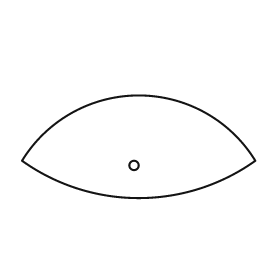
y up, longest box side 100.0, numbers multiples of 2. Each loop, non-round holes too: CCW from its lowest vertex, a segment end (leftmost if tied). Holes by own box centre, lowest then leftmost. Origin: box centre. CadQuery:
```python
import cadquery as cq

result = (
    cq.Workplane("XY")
    .moveTo(-50.0, -6.0)
    .threePointArc((0.0, -22.0), (50.0, -6.0))
    .threePointArc((0.0, 22.0), (-50.0, -6.0))
    .close()
    .moveTo(-2.0, -8.0)
    .circle(2.0)
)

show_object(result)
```